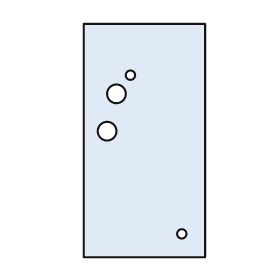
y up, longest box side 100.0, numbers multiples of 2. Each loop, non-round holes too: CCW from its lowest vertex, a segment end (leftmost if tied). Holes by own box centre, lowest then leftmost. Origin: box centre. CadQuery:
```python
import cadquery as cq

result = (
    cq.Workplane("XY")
    .moveTo(-26.0, -50.0)
    .lineTo(26.0, -50.0)
    .lineTo(26.0, 50.0)
    .lineTo(-26.0, 50.0)
    .close()
    .moveTo(16.0, -40.0)
    .circle(2.0)
    .moveTo(-16.0, 4.0)
    .circle(4.0)
    .moveTo(-12.0, 20.0)
    .circle(4.0)
    .moveTo(-6.0, 28.0)
    .circle(2.0)
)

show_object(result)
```